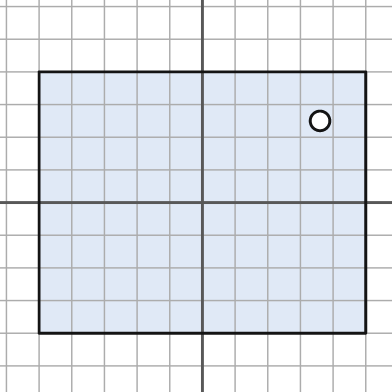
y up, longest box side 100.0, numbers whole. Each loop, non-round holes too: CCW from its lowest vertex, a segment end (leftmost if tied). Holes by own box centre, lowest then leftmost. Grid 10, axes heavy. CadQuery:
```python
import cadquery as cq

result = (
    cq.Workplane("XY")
    .moveTo(-50.0, -40.0)
    .lineTo(50.0, -40.0)
    .lineTo(50.0, 40.0)
    .lineTo(-50.0, 40.0)
    .close()
    .moveTo(36.0, 25.0)
    .circle(3.0)
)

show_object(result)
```